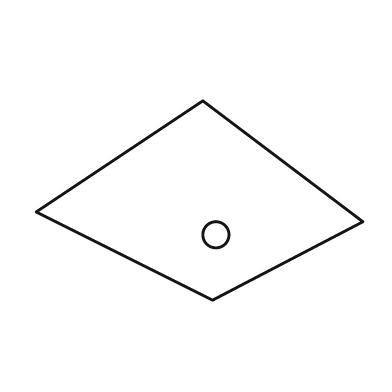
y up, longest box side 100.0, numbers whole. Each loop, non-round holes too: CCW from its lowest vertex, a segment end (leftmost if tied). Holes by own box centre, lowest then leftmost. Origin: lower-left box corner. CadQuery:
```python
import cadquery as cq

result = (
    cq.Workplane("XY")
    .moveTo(54.0, 0.0)
    .lineTo(100.0, 24.0)
    .lineTo(51.0, 61.0)
    .lineTo(0.0, 27.0)
    .close()
    .moveTo(55.0, 20.0)
    .circle(4.0)
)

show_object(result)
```